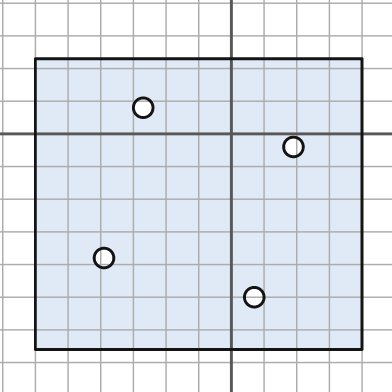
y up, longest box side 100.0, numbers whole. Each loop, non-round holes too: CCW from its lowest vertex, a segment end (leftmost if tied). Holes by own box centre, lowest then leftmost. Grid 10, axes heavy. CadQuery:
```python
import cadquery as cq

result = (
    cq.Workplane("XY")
    .moveTo(-60.0, -66.0)
    .lineTo(40.0, -66.0)
    .lineTo(40.0, 23.0)
    .lineTo(-60.0, 23.0)
    .close()
    .moveTo(7.0, -50.0)
    .circle(3.0)
    .moveTo(-39.0, -38.0)
    .circle(3.0)
    .moveTo(19.0, -4.0)
    .circle(3.0)
    .moveTo(-27.0, 8.0)
    .circle(3.0)
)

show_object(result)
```